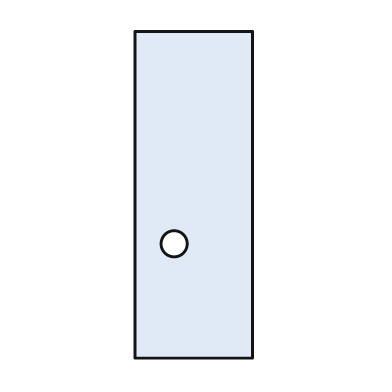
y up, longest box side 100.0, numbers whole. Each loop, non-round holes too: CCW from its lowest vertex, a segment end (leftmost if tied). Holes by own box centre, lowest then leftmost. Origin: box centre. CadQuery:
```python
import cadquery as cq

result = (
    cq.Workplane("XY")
    .moveTo(-18.0, -50.0)
    .lineTo(18.0, -50.0)
    .lineTo(18.0, 50.0)
    .lineTo(-18.0, 50.0)
    .close()
    .moveTo(-6.0, -15.0)
    .circle(4.0)
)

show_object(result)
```